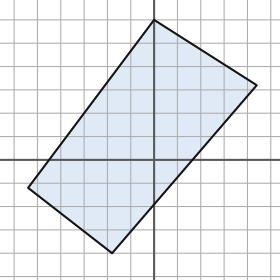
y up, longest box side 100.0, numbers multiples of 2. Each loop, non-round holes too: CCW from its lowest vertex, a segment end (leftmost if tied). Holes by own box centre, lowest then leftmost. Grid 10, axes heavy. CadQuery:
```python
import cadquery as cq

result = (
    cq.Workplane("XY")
    .moveTo(-18.0, -40.0)
    .lineTo(44.0, 32.0)
    .lineTo(0.0, 60.0)
    .lineTo(-54.0, -12.0)
    .close()
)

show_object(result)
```